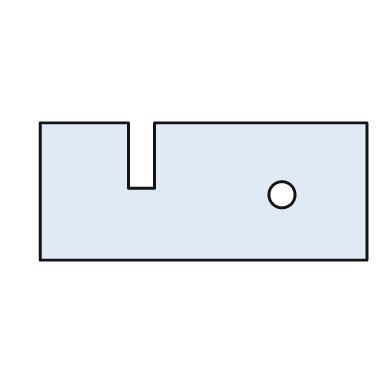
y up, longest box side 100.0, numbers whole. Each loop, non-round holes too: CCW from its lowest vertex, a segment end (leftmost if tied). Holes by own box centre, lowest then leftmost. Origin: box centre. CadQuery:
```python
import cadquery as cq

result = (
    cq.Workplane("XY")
    .moveTo(-50.0, -21.0)
    .lineTo(50.0, -21.0)
    .lineTo(50.0, 21.0)
    .lineTo(-15.0, 21.0)
    .lineTo(-15.0, 1.0)
    .lineTo(-23.0, 1.0)
    .lineTo(-23.0, 21.0)
    .lineTo(-50.0, 21.0)
    .close()
    .moveTo(24.0, -1.0)
    .circle(4.0)
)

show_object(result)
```